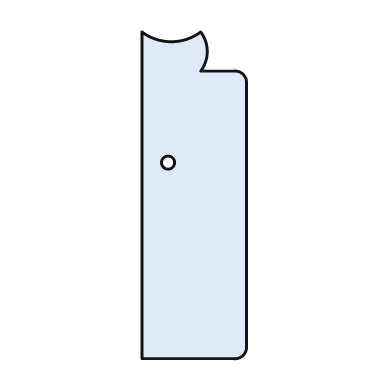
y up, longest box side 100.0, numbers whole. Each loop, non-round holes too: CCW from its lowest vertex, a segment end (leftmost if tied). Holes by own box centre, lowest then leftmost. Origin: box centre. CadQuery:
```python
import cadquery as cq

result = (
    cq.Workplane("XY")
    .moveTo(-16.0, -50.0)
    .lineTo(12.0, -50.0)
    .threePointArc((15.0, -49.0), (16.0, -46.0))
    .lineTo(16.0, 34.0)
    .threePointArc((15.0, 37.0), (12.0, 38.0))
    .lineTo(2.0, 38.0)
    .threePointArc((4.0, 44.0), (2.0, 50.0))
    .threePointArc((-7.0, 47.0), (-16.0, 50.0))
    .close()
    .moveTo(-8.0, 10.0)
    .circle(2.0)
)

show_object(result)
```